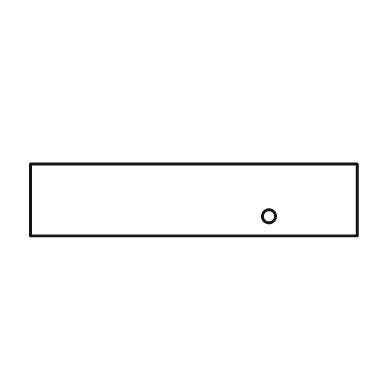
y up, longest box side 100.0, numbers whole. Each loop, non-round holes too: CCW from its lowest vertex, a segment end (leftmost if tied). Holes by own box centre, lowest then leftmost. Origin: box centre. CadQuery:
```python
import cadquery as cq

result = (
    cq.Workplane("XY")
    .moveTo(-50.0, -11.0)
    .lineTo(50.0, -11.0)
    .lineTo(50.0, 11.0)
    .lineTo(-50.0, 11.0)
    .close()
    .moveTo(23.0, -5.0)
    .circle(2.0)
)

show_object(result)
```